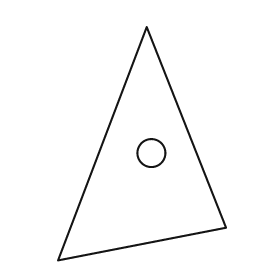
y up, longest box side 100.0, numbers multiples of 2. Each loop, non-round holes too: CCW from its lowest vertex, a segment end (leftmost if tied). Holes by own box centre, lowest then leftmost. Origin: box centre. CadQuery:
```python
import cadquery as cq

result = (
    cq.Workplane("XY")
    .moveTo(-36.0, -50.0)
    .lineTo(36.0, -36.0)
    .lineTo(2.0, 50.0)
    .close()
    .moveTo(4.0, -4.0)
    .circle(6.0)
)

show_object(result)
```